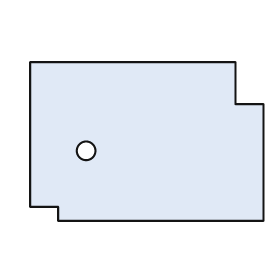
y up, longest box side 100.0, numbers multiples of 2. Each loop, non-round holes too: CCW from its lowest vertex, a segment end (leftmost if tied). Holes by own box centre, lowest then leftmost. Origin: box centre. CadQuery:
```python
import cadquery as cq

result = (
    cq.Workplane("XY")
    .moveTo(-38.0, -34.0)
    .lineTo(50.0, -34.0)
    .lineTo(50.0, 16.0)
    .lineTo(38.0, 16.0)
    .lineTo(38.0, 34.0)
    .lineTo(-50.0, 34.0)
    .lineTo(-50.0, -28.0)
    .lineTo(-38.0, -28.0)
    .close()
    .moveTo(-26.0, -4.0)
    .circle(4.0)
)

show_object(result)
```